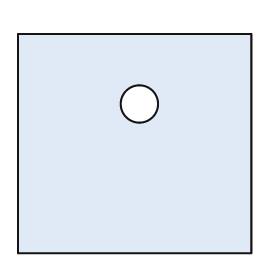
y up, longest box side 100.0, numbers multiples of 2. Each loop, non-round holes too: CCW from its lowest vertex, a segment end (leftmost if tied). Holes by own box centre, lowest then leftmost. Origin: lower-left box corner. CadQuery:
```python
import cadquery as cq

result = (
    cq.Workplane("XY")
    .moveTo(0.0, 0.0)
    .lineTo(100.0, 0.0)
    .lineTo(100.0, 94.0)
    .lineTo(0.0, 94.0)
    .close()
    .moveTo(52.0, 64.0)
    .circle(8.0)
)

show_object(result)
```